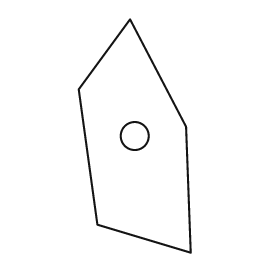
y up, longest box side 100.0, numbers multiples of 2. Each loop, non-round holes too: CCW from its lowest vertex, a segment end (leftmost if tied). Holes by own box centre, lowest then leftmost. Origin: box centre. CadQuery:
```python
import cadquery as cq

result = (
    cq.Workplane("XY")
    .moveTo(24.0, -50.0)
    .lineTo(22.0, 4.0)
    .lineTo(-2.0, 50.0)
    .lineTo(-24.0, 20.0)
    .lineTo(-16.0, -38.0)
    .close()
    .moveTo(0.0, 0.0)
    .circle(6.0)
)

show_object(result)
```